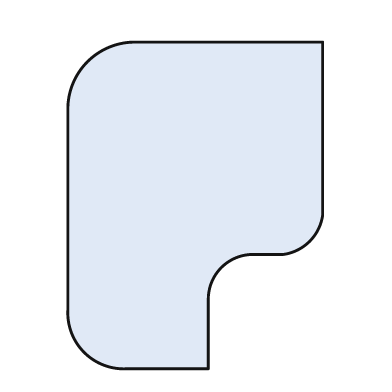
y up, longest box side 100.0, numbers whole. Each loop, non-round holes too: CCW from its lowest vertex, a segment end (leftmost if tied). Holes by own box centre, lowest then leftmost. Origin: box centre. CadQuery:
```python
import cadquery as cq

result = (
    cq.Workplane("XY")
    .moveTo(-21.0, -50.0)
    .lineTo(4.0, -50.0)
    .lineTo(4.0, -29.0)
    .threePointArc((8.0, -19.0), (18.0, -15.0))
    .lineTo(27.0, -15.0)
    .threePointArc((35.0, -11.0), (39.0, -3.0))
    .lineTo(39.0, 50.0)
    .lineTo(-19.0, 50.0)
    .threePointArc((-33.0, 44.0), (-39.0, 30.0))
    .lineTo(-39.0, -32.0)
    .threePointArc((-34.0, -45.0), (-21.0, -50.0))
    .close()
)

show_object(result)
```